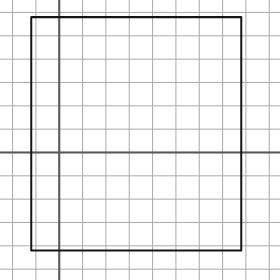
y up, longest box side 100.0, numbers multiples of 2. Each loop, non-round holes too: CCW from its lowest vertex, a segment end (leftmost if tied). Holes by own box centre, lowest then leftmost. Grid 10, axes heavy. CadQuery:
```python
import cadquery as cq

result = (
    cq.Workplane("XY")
    .moveTo(-12.0, -42.0)
    .lineTo(78.0, -42.0)
    .lineTo(78.0, 58.0)
    .lineTo(-12.0, 58.0)
    .close()
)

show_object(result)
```